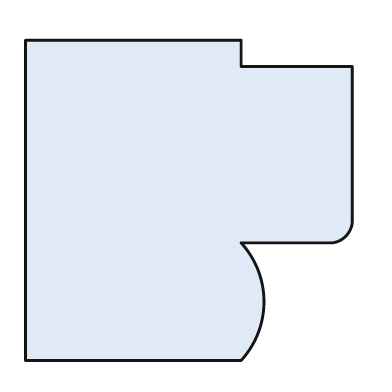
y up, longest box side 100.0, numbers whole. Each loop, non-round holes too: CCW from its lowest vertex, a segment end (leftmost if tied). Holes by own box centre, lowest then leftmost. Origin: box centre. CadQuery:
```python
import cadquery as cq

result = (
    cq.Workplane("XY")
    .moveTo(-50.0, -49.0)
    .lineTo(16.0, -49.0)
    .threePointArc((23.0, -31.0), (16.0, -13.0))
    .lineTo(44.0, -13.0)
    .threePointArc((48.0, -11.0), (50.0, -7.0))
    .lineTo(50.0, 41.0)
    .lineTo(16.0, 41.0)
    .lineTo(16.0, 49.0)
    .lineTo(-50.0, 49.0)
    .close()
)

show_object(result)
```